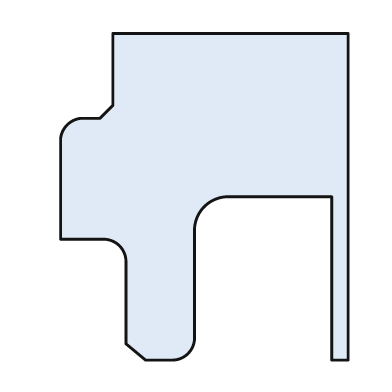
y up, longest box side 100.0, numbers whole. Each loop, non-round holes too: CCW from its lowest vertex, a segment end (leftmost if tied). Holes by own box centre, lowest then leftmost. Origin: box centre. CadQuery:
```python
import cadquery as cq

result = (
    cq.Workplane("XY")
    .moveTo(-18.0, -50.0)
    .lineTo(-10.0, -50.0)
    .threePointArc((-5.0, -48.0), (-3.0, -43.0))
    .lineTo(-3.0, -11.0)
    .threePointArc((0.0, -3.0), (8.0, 0.0))
    .lineTo(39.0, 0.0)
    .lineTo(39.0, -50.0)
    .lineTo(44.0, -50.0)
    .lineTo(44.0, 50.0)
    .lineTo(-28.0, 50.0)
    .lineTo(-28.0, 28.0)
    .lineTo(-32.0, 24.0)
    .lineTo(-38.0, 24.0)
    .threePointArc((-42.0, 22.0), (-44.0, 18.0))
    .lineTo(-44.0, -13.0)
    .lineTo(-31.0, -13.0)
    .threePointArc((-26.0, -15.0), (-24.0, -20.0))
    .lineTo(-24.0, -45.0)
    .close()
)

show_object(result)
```